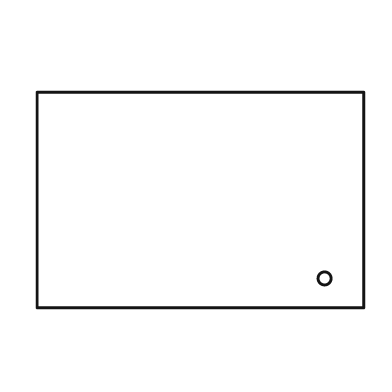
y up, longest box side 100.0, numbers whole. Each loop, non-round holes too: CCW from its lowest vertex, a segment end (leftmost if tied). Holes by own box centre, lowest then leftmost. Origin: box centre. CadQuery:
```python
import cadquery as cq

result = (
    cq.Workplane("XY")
    .moveTo(-50.0, -33.0)
    .lineTo(50.0, -33.0)
    .lineTo(50.0, 33.0)
    .lineTo(-50.0, 33.0)
    .close()
    .moveTo(38.0, -24.0)
    .circle(2.0)
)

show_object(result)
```